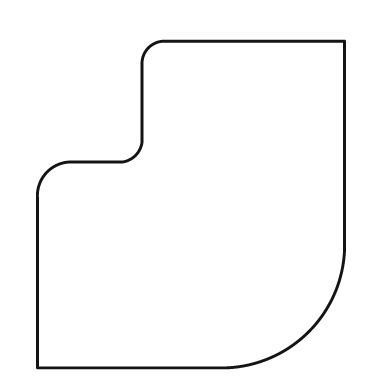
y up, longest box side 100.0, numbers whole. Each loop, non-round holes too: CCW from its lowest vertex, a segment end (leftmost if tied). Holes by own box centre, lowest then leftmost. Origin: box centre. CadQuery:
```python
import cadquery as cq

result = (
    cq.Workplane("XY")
    .moveTo(-47.0, -50.0)
    .lineTo(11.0, -50.0)
    .threePointArc((36.0, -39.0), (47.0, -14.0))
    .lineTo(47.0, 50.0)
    .lineTo(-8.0, 50.0)
    .threePointArc((-13.0, 48.0), (-15.0, 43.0))
    .lineTo(-15.0, 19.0)
    .threePointArc((-17.0, 15.0), (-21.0, 13.0))
    .lineTo(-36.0, 13.0)
    .threePointArc((-44.0, 10.0), (-47.0, 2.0))
    .close()
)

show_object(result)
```